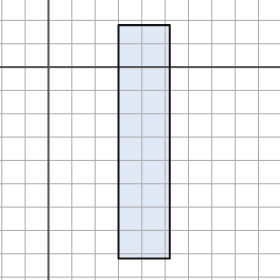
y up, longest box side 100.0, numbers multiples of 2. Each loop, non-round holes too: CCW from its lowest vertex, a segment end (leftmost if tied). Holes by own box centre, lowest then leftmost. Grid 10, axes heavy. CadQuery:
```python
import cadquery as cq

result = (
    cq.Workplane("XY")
    .moveTo(30.0, -82.0)
    .lineTo(52.0, -82.0)
    .lineTo(52.0, 18.0)
    .lineTo(30.0, 18.0)
    .close()
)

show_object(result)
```